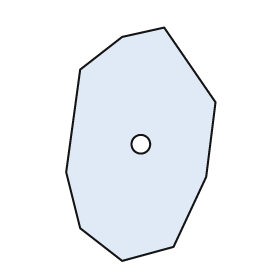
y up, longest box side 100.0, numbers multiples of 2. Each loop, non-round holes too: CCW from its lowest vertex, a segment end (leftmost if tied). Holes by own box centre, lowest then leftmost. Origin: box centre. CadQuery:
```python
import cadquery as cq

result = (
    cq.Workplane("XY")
    .moveTo(-8.0, -50.0)
    .lineTo(14.0, -44.0)
    .lineTo(28.0, -14.0)
    .lineTo(32.0, 18.0)
    .lineTo(10.0, 50.0)
    .lineTo(-8.0, 46.0)
    .lineTo(-26.0, 32.0)
    .lineTo(-32.0, -12.0)
    .lineTo(-26.0, -36.0)
    .close()
    .moveTo(0.0, 0.0)
    .circle(4.0)
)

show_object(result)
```